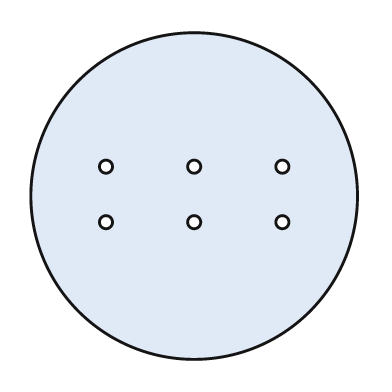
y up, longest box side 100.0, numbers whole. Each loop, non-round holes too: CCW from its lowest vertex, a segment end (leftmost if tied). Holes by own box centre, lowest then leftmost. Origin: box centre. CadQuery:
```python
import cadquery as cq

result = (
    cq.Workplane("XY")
    .moveTo(0.0, 0.0)
    .circle(50.0)
    .moveTo(-27.0, -8.0)
    .circle(2.0)
    .moveTo(0.0, -8.0)
    .circle(2.0)
    .moveTo(27.0, -8.0)
    .circle(2.0)
    .moveTo(-27.0, 9.0)
    .circle(2.0)
    .moveTo(0.0, 9.0)
    .circle(2.0)
    .moveTo(27.0, 9.0)
    .circle(2.0)
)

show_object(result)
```